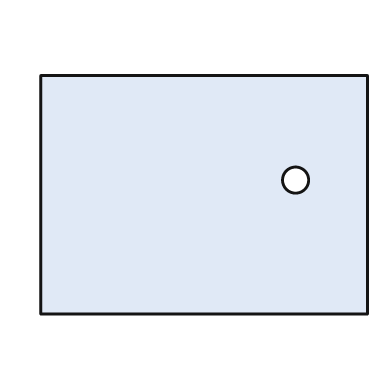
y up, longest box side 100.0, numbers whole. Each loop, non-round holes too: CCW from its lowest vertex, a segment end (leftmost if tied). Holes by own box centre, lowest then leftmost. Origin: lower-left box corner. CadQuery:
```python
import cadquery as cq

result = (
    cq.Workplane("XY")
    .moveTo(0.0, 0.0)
    .lineTo(100.0, 0.0)
    .lineTo(100.0, 73.0)
    .lineTo(0.0, 73.0)
    .close()
    .moveTo(78.0, 41.0)
    .circle(4.0)
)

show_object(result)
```